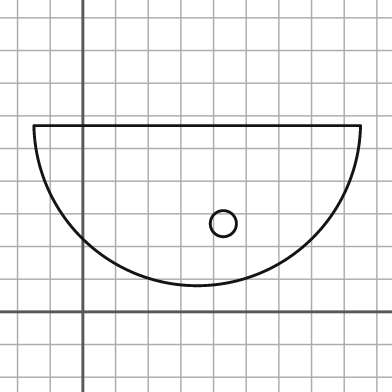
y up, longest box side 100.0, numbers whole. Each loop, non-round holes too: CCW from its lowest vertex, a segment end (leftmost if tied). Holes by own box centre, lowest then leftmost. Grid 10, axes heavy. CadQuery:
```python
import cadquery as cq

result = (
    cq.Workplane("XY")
    .moveTo(-15.0, 57.0)
    .threePointArc((35.0, 8.0), (85.0, 57.0))
    .close()
    .moveTo(43.0, 27.0)
    .circle(4.0)
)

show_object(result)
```